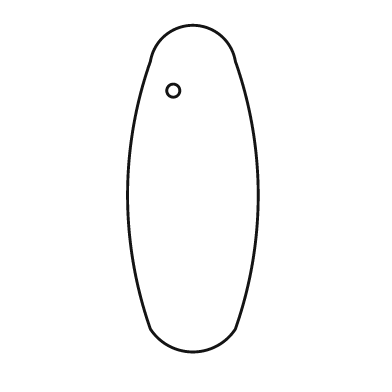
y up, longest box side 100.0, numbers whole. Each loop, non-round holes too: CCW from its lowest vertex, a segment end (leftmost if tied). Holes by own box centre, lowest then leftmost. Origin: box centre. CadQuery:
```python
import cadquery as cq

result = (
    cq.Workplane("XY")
    .moveTo(-13.0, -43.0)
    .threePointArc((0.0, -50.0), (13.0, -43.0))
    .threePointArc((20.0, -2.0), (13.0, 39.0))
    .threePointArc((0.0, 50.0), (-13.0, 39.0))
    .threePointArc((-20.0, -2.0), (-13.0, -43.0))
    .close()
    .moveTo(-6.0, 30.0)
    .circle(2.0)
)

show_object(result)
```